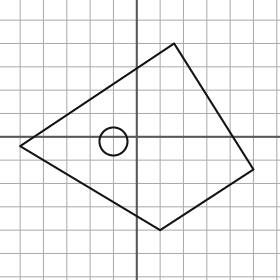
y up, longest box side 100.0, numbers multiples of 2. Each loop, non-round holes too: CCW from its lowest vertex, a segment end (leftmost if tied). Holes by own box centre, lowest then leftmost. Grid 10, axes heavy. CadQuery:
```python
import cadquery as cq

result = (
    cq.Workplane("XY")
    .moveTo(10.0, -40.0)
    .lineTo(50.0, -14.0)
    .lineTo(16.0, 40.0)
    .lineTo(-50.0, -4.0)
    .close()
    .moveTo(-10.0, -2.0)
    .circle(6.0)
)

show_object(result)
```